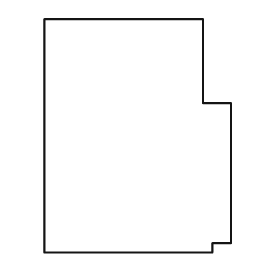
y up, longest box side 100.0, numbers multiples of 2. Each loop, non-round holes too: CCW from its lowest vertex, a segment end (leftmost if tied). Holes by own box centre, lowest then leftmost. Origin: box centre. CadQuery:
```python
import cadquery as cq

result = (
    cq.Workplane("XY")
    .moveTo(-40.0, -50.0)
    .lineTo(32.0, -50.0)
    .lineTo(32.0, -46.0)
    .lineTo(40.0, -46.0)
    .lineTo(40.0, 14.0)
    .lineTo(28.0, 14.0)
    .lineTo(28.0, 50.0)
    .lineTo(-40.0, 50.0)
    .close()
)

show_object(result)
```